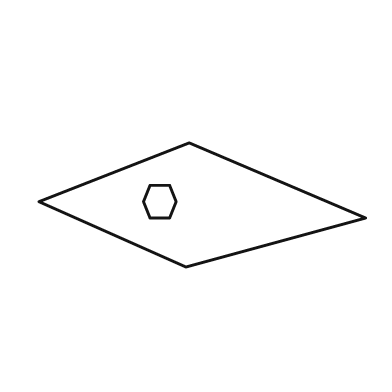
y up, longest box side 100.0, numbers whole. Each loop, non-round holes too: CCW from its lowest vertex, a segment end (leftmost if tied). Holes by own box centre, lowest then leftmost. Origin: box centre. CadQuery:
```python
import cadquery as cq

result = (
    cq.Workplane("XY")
    .moveTo(-5.0, -19.0)
    .lineTo(50.0, -4.0)
    .lineTo(-4.0, 19.0)
    .lineTo(-50.0, 1.0)
    .close()
    .moveTo(-16.0, -4.0)
    .lineTo(-10.0, -4.0)
    .lineTo(-8.0, 1.0)
    .lineTo(-10.0, 6.0)
    .lineTo(-16.0, 6.0)
    .lineTo(-18.0, 1.0)
    .close()
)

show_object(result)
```